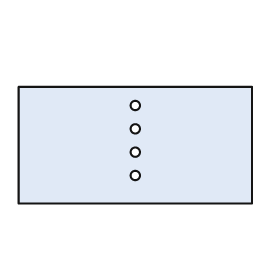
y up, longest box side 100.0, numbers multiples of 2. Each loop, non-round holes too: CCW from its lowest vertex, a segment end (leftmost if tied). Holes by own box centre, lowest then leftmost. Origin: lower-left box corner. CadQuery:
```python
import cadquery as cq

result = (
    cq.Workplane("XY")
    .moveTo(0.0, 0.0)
    .lineTo(100.0, 0.0)
    .lineTo(100.0, 50.0)
    .lineTo(0.0, 50.0)
    .close()
    .moveTo(50.0, 12.0)
    .circle(2.0)
    .moveTo(50.0, 22.0)
    .circle(2.0)
    .moveTo(50.0, 32.0)
    .circle(2.0)
    .moveTo(50.0, 42.0)
    .circle(2.0)
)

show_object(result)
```